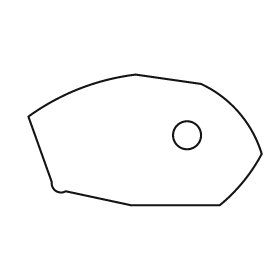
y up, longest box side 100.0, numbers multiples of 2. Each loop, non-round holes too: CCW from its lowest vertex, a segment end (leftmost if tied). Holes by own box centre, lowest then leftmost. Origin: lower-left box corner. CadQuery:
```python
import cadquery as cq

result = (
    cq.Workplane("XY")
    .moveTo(44.0, 0.0)
    .lineTo(82.0, 0.0)
    .threePointArc((92.0, 10.0), (100.0, 22.0))
    .threePointArc((90.0, 40.0), (74.0, 52.0))
    .lineTo(46.0, 56.0)
    .threePointArc((22.0, 50.0), (0.0, 38.0))
    .lineTo(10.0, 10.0)
    .threePointArc((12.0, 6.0), (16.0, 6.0))
    .close()
    .moveTo(68.0, 30.0)
    .circle(6.0)
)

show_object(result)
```